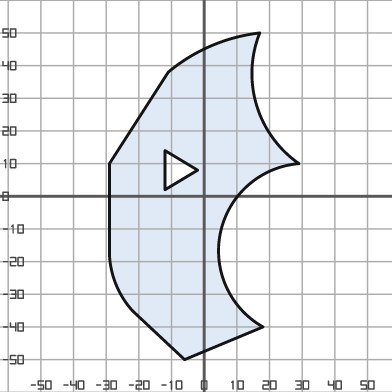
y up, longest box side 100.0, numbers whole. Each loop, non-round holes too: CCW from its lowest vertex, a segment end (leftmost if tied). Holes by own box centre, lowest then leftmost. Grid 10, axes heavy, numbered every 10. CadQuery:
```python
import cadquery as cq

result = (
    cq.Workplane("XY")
    .moveTo(-6.0, -50.0)
    .lineTo(18.0, -40.0)
    .threePointArc((5.0, -11.0), (29.0, 10.0))
    .threePointArc((16.0, 28.0), (17.0, 50.0))
    .threePointArc((2.0, 46.0), (-11.0, 38.0))
    .lineTo(-29.0, 10.0)
    .lineTo(-29.0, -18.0)
    .threePointArc((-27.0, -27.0), (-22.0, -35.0))
    .close()
    .moveTo(-12.0, 2.0)
    .lineTo(-2.0, 8.0)
    .lineTo(-12.0, 14.0)
    .close()
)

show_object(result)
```